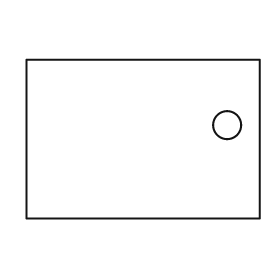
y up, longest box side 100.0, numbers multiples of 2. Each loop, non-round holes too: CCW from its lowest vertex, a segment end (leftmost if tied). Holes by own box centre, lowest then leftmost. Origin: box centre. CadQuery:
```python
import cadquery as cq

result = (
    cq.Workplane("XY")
    .moveTo(-50.0, -34.0)
    .lineTo(50.0, -34.0)
    .lineTo(50.0, 34.0)
    .lineTo(-50.0, 34.0)
    .close()
    .moveTo(36.0, 6.0)
    .circle(6.0)
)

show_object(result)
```